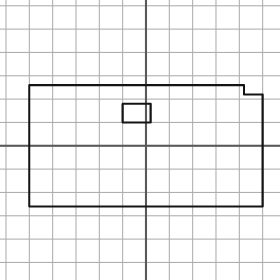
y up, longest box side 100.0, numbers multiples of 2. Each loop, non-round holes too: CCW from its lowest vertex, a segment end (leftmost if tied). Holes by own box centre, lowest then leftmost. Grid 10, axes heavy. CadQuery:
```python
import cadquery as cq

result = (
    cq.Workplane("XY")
    .moveTo(-50.0, -26.0)
    .lineTo(50.0, -26.0)
    .lineTo(50.0, 22.0)
    .lineTo(42.0, 22.0)
    .lineTo(42.0, 26.0)
    .lineTo(-50.0, 26.0)
    .close()
    .moveTo(-10.0, 10.0)
    .lineTo(2.0, 10.0)
    .lineTo(2.0, 18.0)
    .lineTo(-10.0, 18.0)
    .close()
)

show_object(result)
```